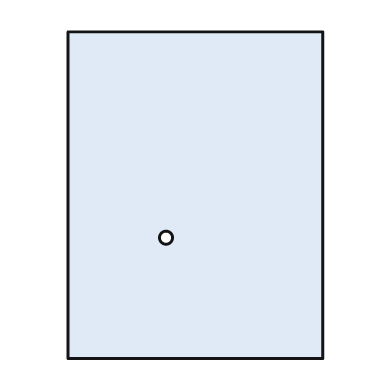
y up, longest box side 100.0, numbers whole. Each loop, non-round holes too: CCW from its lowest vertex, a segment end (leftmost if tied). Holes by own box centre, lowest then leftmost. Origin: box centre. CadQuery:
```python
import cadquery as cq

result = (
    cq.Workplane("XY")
    .moveTo(-39.0, -50.0)
    .lineTo(39.0, -50.0)
    .lineTo(39.0, 50.0)
    .lineTo(-39.0, 50.0)
    .close()
    .moveTo(-9.0, -13.0)
    .circle(2.0)
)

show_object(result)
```